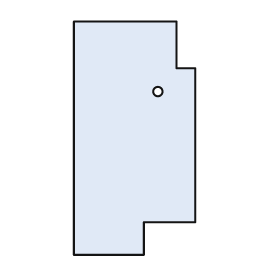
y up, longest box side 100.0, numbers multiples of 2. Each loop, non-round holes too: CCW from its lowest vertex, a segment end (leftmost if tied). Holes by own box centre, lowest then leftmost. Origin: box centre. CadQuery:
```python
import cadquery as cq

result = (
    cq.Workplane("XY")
    .moveTo(-26.0, -50.0)
    .lineTo(4.0, -50.0)
    .lineTo(4.0, -36.0)
    .lineTo(26.0, -36.0)
    .lineTo(26.0, 30.0)
    .lineTo(18.0, 30.0)
    .lineTo(18.0, 50.0)
    .lineTo(-26.0, 50.0)
    .close()
    .moveTo(10.0, 20.0)
    .circle(2.0)
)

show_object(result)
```